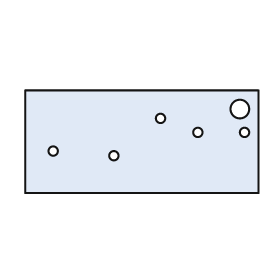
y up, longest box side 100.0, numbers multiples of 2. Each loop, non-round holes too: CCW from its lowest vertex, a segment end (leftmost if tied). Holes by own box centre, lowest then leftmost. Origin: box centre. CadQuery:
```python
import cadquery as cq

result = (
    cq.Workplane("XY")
    .moveTo(-50.0, -22.0)
    .lineTo(50.0, -22.0)
    .lineTo(50.0, 22.0)
    .lineTo(-50.0, 22.0)
    .close()
    .moveTo(-12.0, -6.0)
    .circle(2.0)
    .moveTo(-38.0, -4.0)
    .circle(2.0)
    .moveTo(24.0, 4.0)
    .circle(2.0)
    .moveTo(44.0, 4.0)
    .circle(2.0)
    .moveTo(8.0, 10.0)
    .circle(2.0)
    .moveTo(42.0, 14.0)
    .circle(4.0)
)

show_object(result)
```